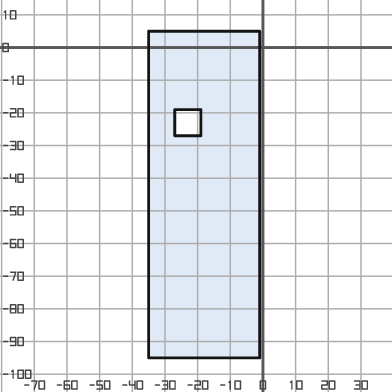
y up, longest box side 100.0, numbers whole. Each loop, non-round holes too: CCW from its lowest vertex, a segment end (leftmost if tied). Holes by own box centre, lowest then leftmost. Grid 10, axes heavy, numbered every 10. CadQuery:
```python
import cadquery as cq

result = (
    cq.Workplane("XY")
    .moveTo(-35.0, -95.0)
    .lineTo(-1.0, -95.0)
    .lineTo(-1.0, 5.0)
    .lineTo(-35.0, 5.0)
    .close()
    .moveTo(-27.0, -27.0)
    .lineTo(-19.0, -27.0)
    .lineTo(-19.0, -19.0)
    .lineTo(-27.0, -19.0)
    .close()
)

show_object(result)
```